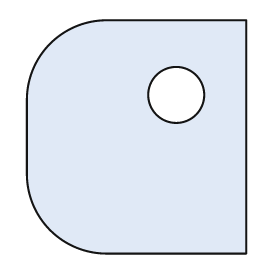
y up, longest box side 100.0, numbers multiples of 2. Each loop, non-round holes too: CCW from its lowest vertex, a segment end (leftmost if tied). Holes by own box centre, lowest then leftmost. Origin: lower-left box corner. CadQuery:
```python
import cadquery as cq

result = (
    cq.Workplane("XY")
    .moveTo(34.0, 0.0)
    .lineTo(94.0, 0.0)
    .lineTo(94.0, 100.0)
    .lineTo(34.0, 100.0)
    .threePointArc((10.0, 90.0), (0.0, 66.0))
    .lineTo(0.0, 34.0)
    .threePointArc((10.0, 10.0), (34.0, 0.0))
    .close()
    .moveTo(64.0, 68.0)
    .circle(12.0)
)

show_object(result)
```